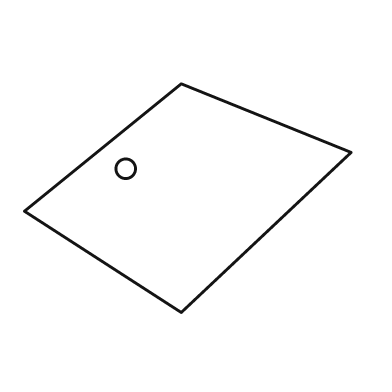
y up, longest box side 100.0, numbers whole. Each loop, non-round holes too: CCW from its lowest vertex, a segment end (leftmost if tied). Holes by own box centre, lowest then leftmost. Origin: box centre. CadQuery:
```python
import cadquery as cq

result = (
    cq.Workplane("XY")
    .moveTo(-2.0, -35.0)
    .lineTo(50.0, 14.0)
    .lineTo(-2.0, 35.0)
    .lineTo(-50.0, -4.0)
    .close()
    .moveTo(-19.0, 9.0)
    .circle(3.0)
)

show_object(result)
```